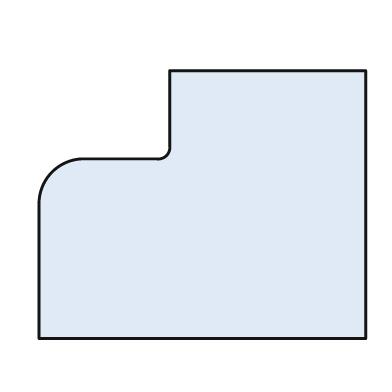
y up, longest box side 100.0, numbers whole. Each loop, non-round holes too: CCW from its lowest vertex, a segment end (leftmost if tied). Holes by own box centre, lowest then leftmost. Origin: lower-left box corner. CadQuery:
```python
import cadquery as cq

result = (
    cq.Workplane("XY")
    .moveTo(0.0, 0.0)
    .lineTo(100.0, 0.0)
    .lineTo(100.0, 82.0)
    .lineTo(40.0, 82.0)
    .lineTo(40.0, 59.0)
    .threePointArc((39.0, 56.0), (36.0, 55.0))
    .lineTo(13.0, 55.0)
    .threePointArc((4.0, 51.0), (0.0, 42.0))
    .close()
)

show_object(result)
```